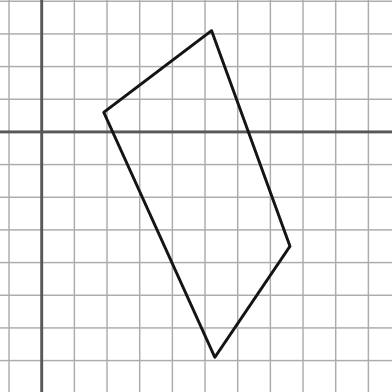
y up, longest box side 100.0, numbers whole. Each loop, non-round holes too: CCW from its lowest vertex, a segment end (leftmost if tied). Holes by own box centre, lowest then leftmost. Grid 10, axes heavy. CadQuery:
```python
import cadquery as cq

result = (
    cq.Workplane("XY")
    .moveTo(53.0, -69.0)
    .lineTo(76.0, -35.0)
    .lineTo(52.0, 31.0)
    .lineTo(19.0, 6.0)
    .close()
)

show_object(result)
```